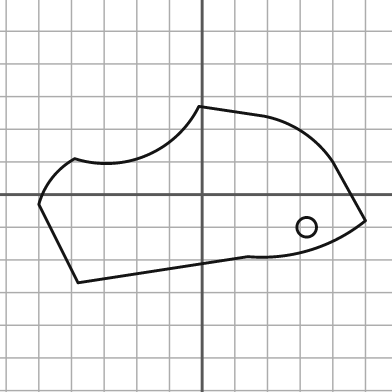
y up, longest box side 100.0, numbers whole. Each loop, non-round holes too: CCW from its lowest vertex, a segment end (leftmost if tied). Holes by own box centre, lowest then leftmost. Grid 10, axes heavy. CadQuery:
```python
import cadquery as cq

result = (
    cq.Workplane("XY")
    .moveTo(-38.0, -27.0)
    .lineTo(14.0, -19.0)
    .threePointArc((33.0, -17.0), (50.0, -8.0))
    .lineTo(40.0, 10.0)
    .threePointArc((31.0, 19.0), (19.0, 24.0))
    .lineTo(-1.0, 27.0)
    .threePointArc((-17.0, 12.0), (-39.0, 11.0))
    .threePointArc((-46.0, 5.0), (-50.0, -3.0))
    .close()
    .moveTo(32.0, -10.0)
    .circle(3.0)
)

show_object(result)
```